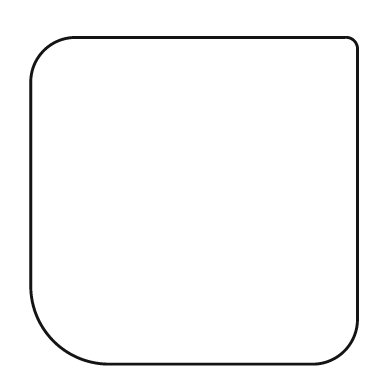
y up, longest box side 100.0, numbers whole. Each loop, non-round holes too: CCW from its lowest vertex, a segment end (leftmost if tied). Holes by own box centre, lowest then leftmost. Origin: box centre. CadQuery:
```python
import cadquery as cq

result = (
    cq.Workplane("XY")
    .moveTo(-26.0, -50.0)
    .lineTo(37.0, -50.0)
    .threePointArc((46.0, -46.0), (50.0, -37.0))
    .lineTo(50.0, 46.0)
    .threePointArc((49.0, 49.0), (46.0, 50.0))
    .lineTo(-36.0, 50.0)
    .threePointArc((-46.0, 46.0), (-50.0, 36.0))
    .lineTo(-50.0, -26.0)
    .threePointArc((-43.0, -43.0), (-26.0, -50.0))
    .close()
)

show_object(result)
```